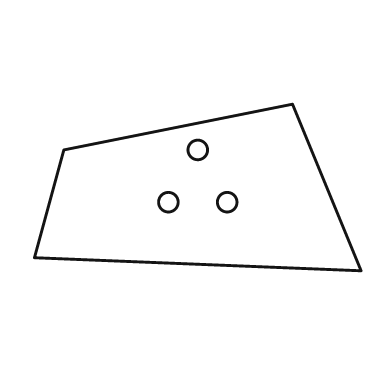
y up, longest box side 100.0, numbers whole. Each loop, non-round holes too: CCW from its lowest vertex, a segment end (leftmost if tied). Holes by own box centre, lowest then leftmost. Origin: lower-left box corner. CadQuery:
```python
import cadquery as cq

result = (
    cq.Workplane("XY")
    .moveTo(100.0, 0.0)
    .lineTo(79.0, 51.0)
    .lineTo(9.0, 37.0)
    .lineTo(0.0, 4.0)
    .close()
    .moveTo(41.0, 21.0)
    .circle(3.0)
    .moveTo(59.0, 21.0)
    .circle(3.0)
    .moveTo(50.0, 37.0)
    .circle(3.0)
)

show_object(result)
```